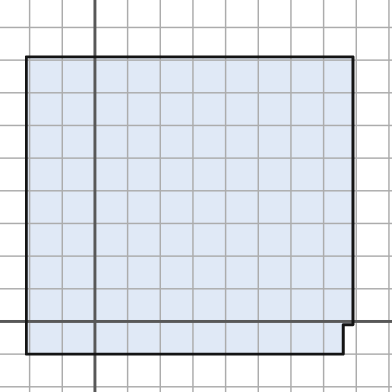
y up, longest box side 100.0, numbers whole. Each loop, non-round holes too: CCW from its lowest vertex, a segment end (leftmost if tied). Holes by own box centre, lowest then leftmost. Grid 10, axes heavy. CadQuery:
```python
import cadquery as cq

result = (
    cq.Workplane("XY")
    .moveTo(-21.0, -10.0)
    .lineTo(76.0, -10.0)
    .lineTo(76.0, -1.0)
    .lineTo(79.0, -1.0)
    .lineTo(79.0, 81.0)
    .lineTo(-21.0, 81.0)
    .close()
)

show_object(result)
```